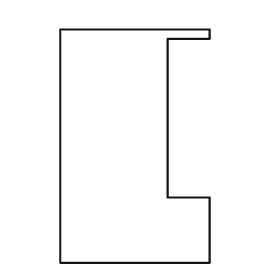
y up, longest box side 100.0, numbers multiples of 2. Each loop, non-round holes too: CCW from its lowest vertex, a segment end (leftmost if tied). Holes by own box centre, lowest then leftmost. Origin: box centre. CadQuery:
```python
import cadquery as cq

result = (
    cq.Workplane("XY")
    .moveTo(-32.0, -50.0)
    .lineTo(32.0, -50.0)
    .lineTo(32.0, -22.0)
    .lineTo(14.0, -22.0)
    .lineTo(14.0, 46.0)
    .lineTo(32.0, 46.0)
    .lineTo(32.0, 50.0)
    .lineTo(-32.0, 50.0)
    .close()
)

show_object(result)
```